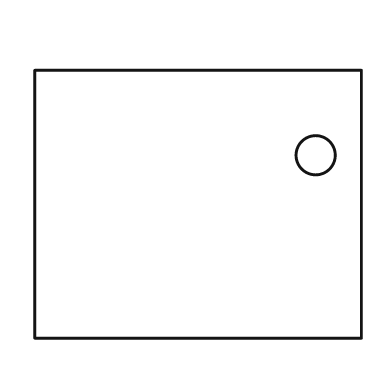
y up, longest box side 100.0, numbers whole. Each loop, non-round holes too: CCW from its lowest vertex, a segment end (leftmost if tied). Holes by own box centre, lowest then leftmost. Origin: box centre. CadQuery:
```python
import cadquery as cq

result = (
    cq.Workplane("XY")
    .moveTo(-50.0, -41.0)
    .lineTo(50.0, -41.0)
    .lineTo(50.0, 41.0)
    .lineTo(-50.0, 41.0)
    .close()
    .moveTo(36.0, 15.0)
    .circle(6.0)
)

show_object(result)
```